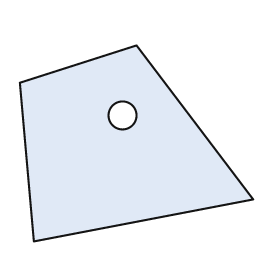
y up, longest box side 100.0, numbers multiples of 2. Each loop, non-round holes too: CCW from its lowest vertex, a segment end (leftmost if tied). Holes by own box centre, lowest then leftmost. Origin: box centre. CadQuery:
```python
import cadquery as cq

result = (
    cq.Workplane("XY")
    .moveTo(-44.0, -42.0)
    .lineTo(50.0, -24.0)
    .lineTo(0.0, 42.0)
    .lineTo(-50.0, 26.0)
    .close()
    .moveTo(-6.0, 12.0)
    .circle(6.0)
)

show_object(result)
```